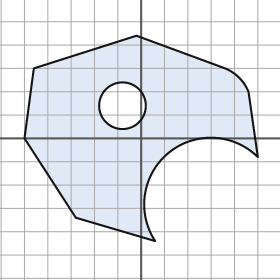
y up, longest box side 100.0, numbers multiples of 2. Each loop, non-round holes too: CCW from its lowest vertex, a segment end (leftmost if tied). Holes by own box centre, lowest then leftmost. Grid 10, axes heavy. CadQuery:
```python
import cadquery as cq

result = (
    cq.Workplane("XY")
    .moveTo(6.0, -44.0)
    .threePointArc((12.0, -6.0), (50.0, -8.0))
    .lineTo(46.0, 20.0)
    .threePointArc((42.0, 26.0), (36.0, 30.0))
    .lineTo(-2.0, 44.0)
    .lineTo(-46.0, 30.0)
    .lineTo(-50.0, 0.0)
    .lineTo(-28.0, -34.0)
    .close()
    .moveTo(-8.0, 14.0)
    .circle(10.0)
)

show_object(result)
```